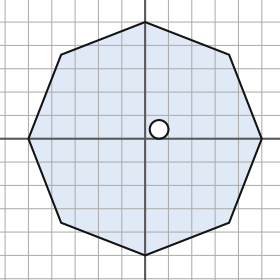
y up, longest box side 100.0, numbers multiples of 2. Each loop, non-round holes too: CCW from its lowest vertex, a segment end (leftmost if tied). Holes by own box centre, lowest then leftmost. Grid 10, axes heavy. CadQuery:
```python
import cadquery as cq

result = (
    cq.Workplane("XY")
    .moveTo(0.0, -50.0)
    .lineTo(36.0, -36.0)
    .lineTo(50.0, 0.0)
    .lineTo(36.0, 36.0)
    .lineTo(0.0, 50.0)
    .lineTo(-36.0, 36.0)
    .lineTo(-50.0, 0.0)
    .lineTo(-36.0, -36.0)
    .close()
    .moveTo(6.0, 4.0)
    .circle(4.0)
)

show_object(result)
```